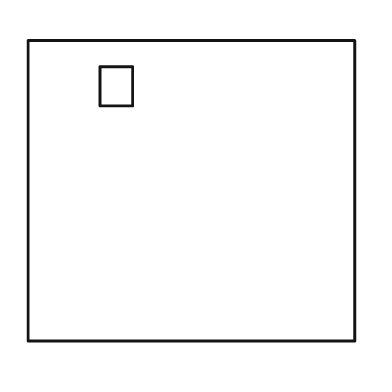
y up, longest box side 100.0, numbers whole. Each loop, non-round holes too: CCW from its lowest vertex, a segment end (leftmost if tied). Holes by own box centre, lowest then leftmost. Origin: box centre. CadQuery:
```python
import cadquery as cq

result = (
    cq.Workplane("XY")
    .moveTo(-50.0, -46.0)
    .lineTo(50.0, -46.0)
    .lineTo(50.0, 46.0)
    .lineTo(-50.0, 46.0)
    .close()
    .moveTo(-28.0, 26.0)
    .lineTo(-18.0, 26.0)
    .lineTo(-18.0, 38.0)
    .lineTo(-28.0, 38.0)
    .close()
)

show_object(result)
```